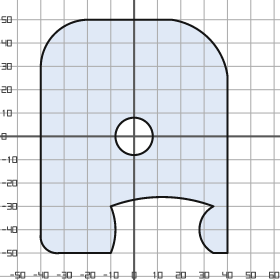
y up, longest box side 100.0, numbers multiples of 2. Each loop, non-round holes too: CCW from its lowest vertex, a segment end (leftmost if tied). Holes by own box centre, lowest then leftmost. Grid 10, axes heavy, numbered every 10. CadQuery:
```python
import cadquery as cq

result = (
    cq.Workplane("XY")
    .moveTo(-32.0, -50.0)
    .lineTo(-10.0, -50.0)
    .threePointArc((-8.0, -40.0), (-10.0, -30.0))
    .threePointArc((12.0, -26.0), (34.0, -30.0))
    .threePointArc((28.0, -40.0), (34.0, -50.0))
    .lineTo(40.0, -50.0)
    .lineTo(40.0, 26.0)
    .threePointArc((32.0, 42.0), (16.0, 50.0))
    .lineTo(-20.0, 50.0)
    .threePointArc((-34.0, 44.0), (-40.0, 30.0))
    .lineTo(-40.0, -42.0)
    .threePointArc((-38.0, -48.0), (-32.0, -50.0))
    .close()
    .moveTo(0.0, 0.0)
    .circle(8.0)
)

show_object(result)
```